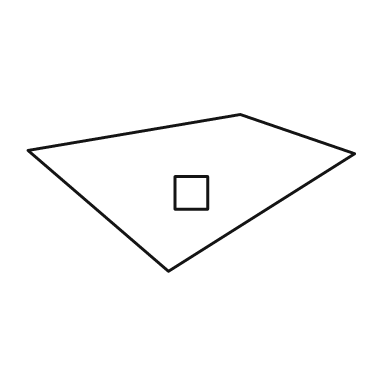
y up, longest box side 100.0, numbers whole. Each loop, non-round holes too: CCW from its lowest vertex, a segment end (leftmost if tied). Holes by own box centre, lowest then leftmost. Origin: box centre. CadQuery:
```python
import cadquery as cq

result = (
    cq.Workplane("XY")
    .moveTo(-7.0, -24.0)
    .lineTo(50.0, 12.0)
    .lineTo(15.0, 24.0)
    .lineTo(-50.0, 13.0)
    .close()
    .moveTo(-5.0, -5.0)
    .lineTo(5.0, -5.0)
    .lineTo(5.0, 5.0)
    .lineTo(-5.0, 5.0)
    .close()
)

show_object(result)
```